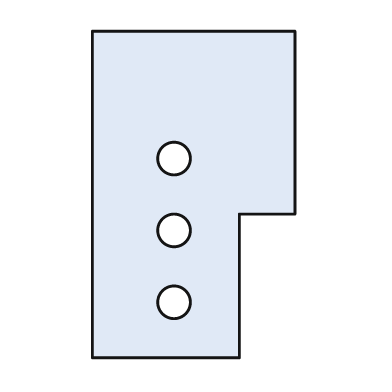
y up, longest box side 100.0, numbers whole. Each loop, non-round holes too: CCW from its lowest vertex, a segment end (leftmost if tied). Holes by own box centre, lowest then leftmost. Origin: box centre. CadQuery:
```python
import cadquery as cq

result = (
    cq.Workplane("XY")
    .moveTo(-31.0, -50.0)
    .lineTo(14.0, -50.0)
    .lineTo(14.0, -6.0)
    .lineTo(31.0, -6.0)
    .lineTo(31.0, 50.0)
    .lineTo(-31.0, 50.0)
    .close()
    .moveTo(-6.0, -33.0)
    .circle(5.0)
    .moveTo(-6.0, -11.0)
    .circle(5.0)
    .moveTo(-6.0, 11.0)
    .circle(5.0)
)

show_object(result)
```